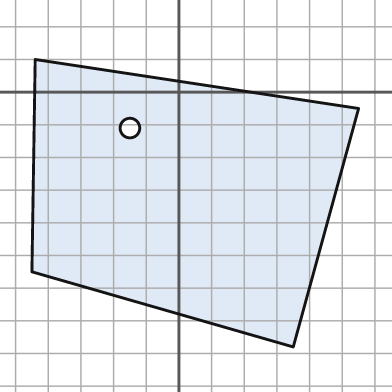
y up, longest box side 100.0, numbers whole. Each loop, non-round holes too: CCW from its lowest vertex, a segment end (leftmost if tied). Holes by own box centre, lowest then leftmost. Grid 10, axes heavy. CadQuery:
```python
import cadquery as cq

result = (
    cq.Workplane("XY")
    .moveTo(35.0, -78.0)
    .lineTo(55.0, -5.0)
    .lineTo(-44.0, 10.0)
    .lineTo(-45.0, -55.0)
    .close()
    .moveTo(-15.0, -11.0)
    .circle(3.0)
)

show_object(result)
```